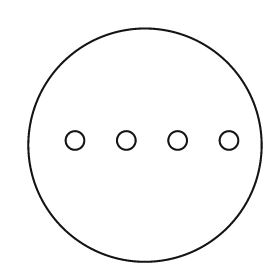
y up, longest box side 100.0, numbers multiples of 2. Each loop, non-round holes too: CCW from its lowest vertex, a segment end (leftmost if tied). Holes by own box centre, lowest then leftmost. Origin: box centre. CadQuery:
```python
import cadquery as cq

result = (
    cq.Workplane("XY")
    .moveTo(0.0, 0.0)
    .circle(50.0)
    .moveTo(-30.0, 2.0)
    .circle(4.0)
    .moveTo(-8.0, 2.0)
    .circle(4.0)
    .moveTo(14.0, 2.0)
    .circle(4.0)
    .moveTo(36.0, 2.0)
    .circle(4.0)
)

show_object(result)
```